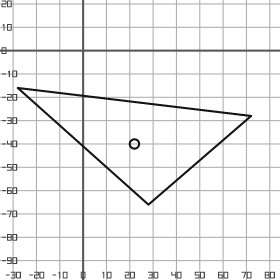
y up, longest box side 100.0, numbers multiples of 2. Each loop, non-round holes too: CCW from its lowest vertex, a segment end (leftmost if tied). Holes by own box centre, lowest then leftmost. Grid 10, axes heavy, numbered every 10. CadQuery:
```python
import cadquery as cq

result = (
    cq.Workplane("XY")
    .moveTo(28.0, -66.0)
    .lineTo(72.0, -28.0)
    .lineTo(-28.0, -16.0)
    .close()
    .moveTo(22.0, -40.0)
    .circle(2.0)
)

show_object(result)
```